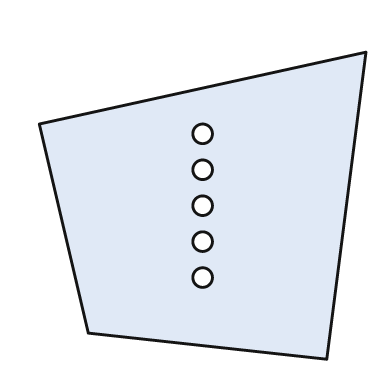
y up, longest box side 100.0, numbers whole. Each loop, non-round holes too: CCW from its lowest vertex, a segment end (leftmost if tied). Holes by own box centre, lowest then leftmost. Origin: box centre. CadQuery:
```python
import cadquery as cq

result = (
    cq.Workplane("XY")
    .moveTo(38.0, -47.0)
    .lineTo(50.0, 47.0)
    .lineTo(-50.0, 25.0)
    .lineTo(-35.0, -39.0)
    .close()
    .moveTo(0.0, -22.0)
    .circle(3.0)
    .moveTo(0.0, -11.0)
    .circle(3.0)
    .moveTo(0.0, 0.0)
    .circle(3.0)
    .moveTo(0.0, 11.0)
    .circle(3.0)
    .moveTo(0.0, 22.0)
    .circle(3.0)
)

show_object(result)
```